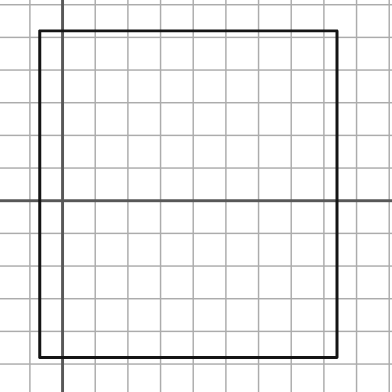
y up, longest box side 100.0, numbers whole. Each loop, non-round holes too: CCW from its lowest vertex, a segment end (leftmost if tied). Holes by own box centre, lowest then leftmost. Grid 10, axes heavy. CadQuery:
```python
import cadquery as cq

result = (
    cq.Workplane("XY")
    .moveTo(-7.0, -48.0)
    .lineTo(84.0, -48.0)
    .lineTo(84.0, 52.0)
    .lineTo(-7.0, 52.0)
    .close()
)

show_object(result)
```